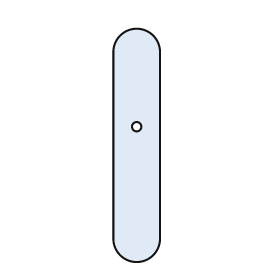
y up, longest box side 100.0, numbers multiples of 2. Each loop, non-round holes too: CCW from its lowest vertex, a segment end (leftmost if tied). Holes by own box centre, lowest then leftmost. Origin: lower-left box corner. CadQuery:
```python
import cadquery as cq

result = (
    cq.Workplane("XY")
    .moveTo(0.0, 10.0)
    .threePointArc((10.0, 0.0), (20.0, 10.0))
    .lineTo(20.0, 90.0)
    .threePointArc((10.0, 100.0), (0.0, 90.0))
    .close()
    .moveTo(10.0, 58.0)
    .circle(2.0)
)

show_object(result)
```